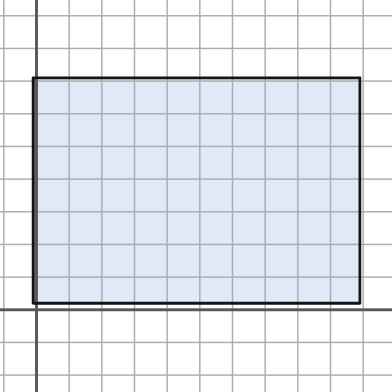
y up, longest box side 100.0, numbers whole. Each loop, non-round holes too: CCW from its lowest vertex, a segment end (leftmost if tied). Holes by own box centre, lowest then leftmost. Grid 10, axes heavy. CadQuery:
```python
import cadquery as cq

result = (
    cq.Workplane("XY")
    .moveTo(-1.0, 2.0)
    .lineTo(99.0, 2.0)
    .lineTo(99.0, 71.0)
    .lineTo(-1.0, 71.0)
    .close()
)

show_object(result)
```